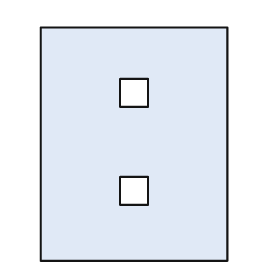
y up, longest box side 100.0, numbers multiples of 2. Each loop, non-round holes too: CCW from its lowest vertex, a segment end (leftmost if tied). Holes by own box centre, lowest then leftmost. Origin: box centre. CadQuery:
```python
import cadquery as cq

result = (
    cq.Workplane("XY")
    .moveTo(-40.0, -50.0)
    .lineTo(40.0, -50.0)
    .lineTo(40.0, 50.0)
    .lineTo(-40.0, 50.0)
    .close()
    .moveTo(-6.0, -26.0)
    .lineTo(6.0, -26.0)
    .lineTo(6.0, -14.0)
    .lineTo(-6.0, -14.0)
    .close()
    .moveTo(-6.0, 16.0)
    .lineTo(6.0, 16.0)
    .lineTo(6.0, 28.0)
    .lineTo(-6.0, 28.0)
    .close()
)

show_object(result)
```